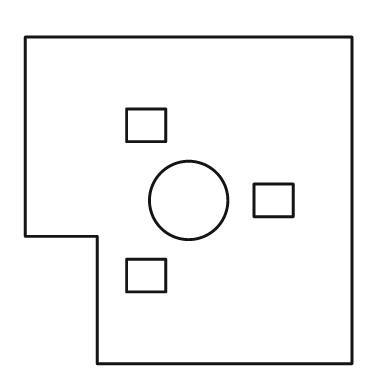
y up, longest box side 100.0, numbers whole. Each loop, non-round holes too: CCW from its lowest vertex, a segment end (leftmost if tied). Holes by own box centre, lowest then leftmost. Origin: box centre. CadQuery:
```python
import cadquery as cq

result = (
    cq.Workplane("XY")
    .moveTo(-28.0, -50.0)
    .lineTo(50.0, -50.0)
    .lineTo(50.0, 50.0)
    .lineTo(-50.0, 50.0)
    .lineTo(-50.0, -11.0)
    .lineTo(-28.0, -11.0)
    .close()
    .moveTo(-19.0, -28.0)
    .lineTo(-7.0, -28.0)
    .lineTo(-7.0, -18.0)
    .lineTo(-19.0, -18.0)
    .close()
    .moveTo(0.0, 0.0)
    .circle(12.0)
    .moveTo(20.0, -5.0)
    .lineTo(32.0, -5.0)
    .lineTo(32.0, 5.0)
    .lineTo(20.0, 5.0)
    .close()
    .moveTo(-19.0, 18.0)
    .lineTo(-7.0, 18.0)
    .lineTo(-7.0, 28.0)
    .lineTo(-19.0, 28.0)
    .close()
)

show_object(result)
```